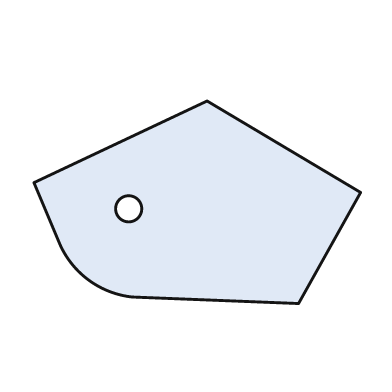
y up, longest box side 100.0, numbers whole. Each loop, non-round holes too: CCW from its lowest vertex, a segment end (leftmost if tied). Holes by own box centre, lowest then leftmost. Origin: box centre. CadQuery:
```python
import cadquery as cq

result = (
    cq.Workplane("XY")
    .moveTo(31.0, -31.0)
    .lineTo(50.0, 3.0)
    .lineTo(3.0, 31.0)
    .lineTo(-50.0, 6.0)
    .lineTo(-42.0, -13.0)
    .threePointArc((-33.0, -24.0), (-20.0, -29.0))
    .close()
    .moveTo(-21.0, -2.0)
    .circle(4.0)
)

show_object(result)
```